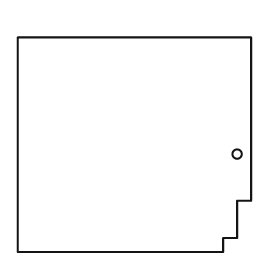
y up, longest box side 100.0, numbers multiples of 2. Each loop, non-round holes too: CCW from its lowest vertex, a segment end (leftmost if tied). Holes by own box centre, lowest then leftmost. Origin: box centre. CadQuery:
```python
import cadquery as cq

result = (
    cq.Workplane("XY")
    .moveTo(-50.0, -46.0)
    .lineTo(38.0, -46.0)
    .lineTo(38.0, -40.0)
    .lineTo(44.0, -40.0)
    .lineTo(44.0, -24.0)
    .lineTo(50.0, -24.0)
    .lineTo(50.0, 46.0)
    .lineTo(-50.0, 46.0)
    .close()
    .moveTo(44.0, -4.0)
    .circle(2.0)
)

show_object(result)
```